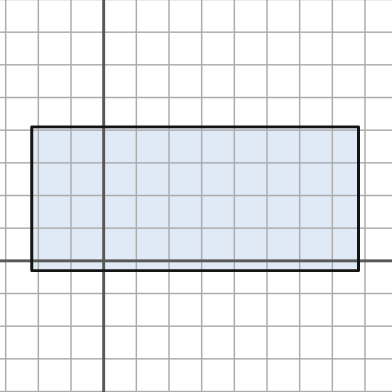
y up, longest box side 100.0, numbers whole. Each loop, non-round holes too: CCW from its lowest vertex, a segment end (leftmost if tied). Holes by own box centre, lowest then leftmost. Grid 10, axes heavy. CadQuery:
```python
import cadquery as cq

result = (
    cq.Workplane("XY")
    .moveTo(-22.0, -3.0)
    .lineTo(78.0, -3.0)
    .lineTo(78.0, 41.0)
    .lineTo(-22.0, 41.0)
    .close()
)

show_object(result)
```